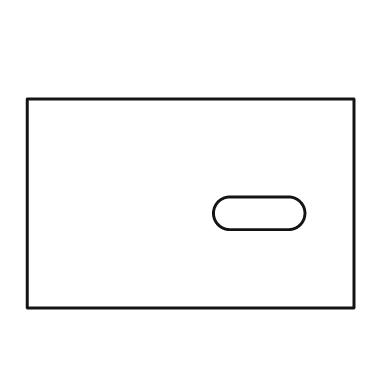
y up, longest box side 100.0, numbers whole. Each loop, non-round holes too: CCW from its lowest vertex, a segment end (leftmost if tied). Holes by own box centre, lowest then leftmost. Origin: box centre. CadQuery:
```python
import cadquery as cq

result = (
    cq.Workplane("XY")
    .moveTo(-50.0, -32.0)
    .lineTo(50.0, -32.0)
    .lineTo(50.0, 32.0)
    .lineTo(-50.0, 32.0)
    .close()
    .moveTo(12.0, -8.0)
    .lineTo(30.0, -8.0)
    .threePointArc((35.0, -3.0), (30.0, 2.0))
    .lineTo(12.0, 2.0)
    .threePointArc((7.0, -3.0), (12.0, -8.0))
    .close()
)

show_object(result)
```